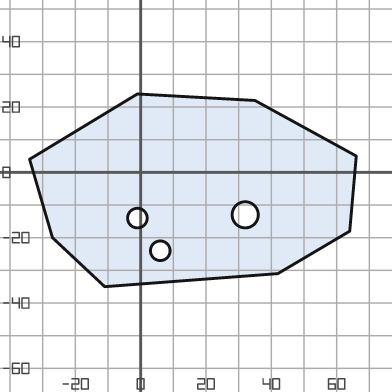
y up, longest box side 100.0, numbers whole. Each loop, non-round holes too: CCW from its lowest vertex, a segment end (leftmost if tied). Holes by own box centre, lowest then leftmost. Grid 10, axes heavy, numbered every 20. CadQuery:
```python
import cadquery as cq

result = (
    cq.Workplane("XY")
    .moveTo(-11.0, -35.0)
    .lineTo(42.0, -31.0)
    .lineTo(64.0, -18.0)
    .lineTo(66.0, 5.0)
    .lineTo(35.0, 22.0)
    .lineTo(-1.0, 24.0)
    .lineTo(-34.0, 4.0)
    .lineTo(-27.0, -20.0)
    .close()
    .moveTo(6.0, -24.0)
    .circle(3.0)
    .moveTo(-1.0, -14.0)
    .circle(3.0)
    .moveTo(32.0, -13.0)
    .circle(4.0)
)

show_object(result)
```